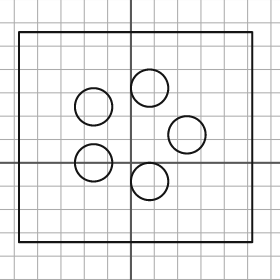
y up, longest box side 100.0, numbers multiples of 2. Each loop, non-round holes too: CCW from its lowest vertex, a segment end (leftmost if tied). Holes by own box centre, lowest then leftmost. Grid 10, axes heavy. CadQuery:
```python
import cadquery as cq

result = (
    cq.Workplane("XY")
    .moveTo(-48.0, -34.0)
    .lineTo(52.0, -34.0)
    .lineTo(52.0, 56.0)
    .lineTo(-48.0, 56.0)
    .close()
    .moveTo(8.0, -8.0)
    .circle(8.0)
    .moveTo(-16.0, 0.0)
    .circle(8.0)
    .moveTo(24.0, 12.0)
    .circle(8.0)
    .moveTo(-16.0, 24.0)
    .circle(8.0)
    .moveTo(8.0, 32.0)
    .circle(8.0)
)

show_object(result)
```